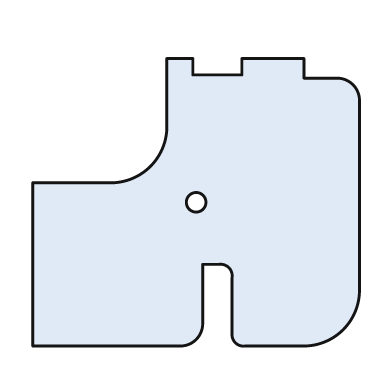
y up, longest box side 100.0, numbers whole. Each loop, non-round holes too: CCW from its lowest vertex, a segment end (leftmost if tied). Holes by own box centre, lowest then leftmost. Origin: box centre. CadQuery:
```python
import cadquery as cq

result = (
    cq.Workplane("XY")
    .moveTo(-50.0, -44.0)
    .lineTo(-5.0, -44.0)
    .threePointArc((0.0, -42.0), (2.0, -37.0))
    .lineTo(2.0, -19.0)
    .lineTo(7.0, -19.0)
    .threePointArc((10.0, -20.0), (11.0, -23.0))
    .lineTo(11.0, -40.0)
    .threePointArc((12.0, -43.0), (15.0, -44.0))
    .lineTo(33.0, -44.0)
    .threePointArc((45.0, -39.0), (50.0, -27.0))
    .lineTo(50.0, 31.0)
    .threePointArc((48.0, 36.0), (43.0, 38.0))
    .lineTo(33.0, 38.0)
    .lineTo(33.0, 44.0)
    .lineTo(14.0, 44.0)
    .lineTo(14.0, 39.0)
    .lineTo(-1.0, 39.0)
    .lineTo(-1.0, 44.0)
    .lineTo(-9.0, 44.0)
    .lineTo(-9.0, 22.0)
    .threePointArc((-14.0, 11.0), (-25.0, 6.0))
    .lineTo(-50.0, 6.0)
    .close()
    .moveTo(0.0, 0.0)
    .circle(3.0)
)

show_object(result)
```